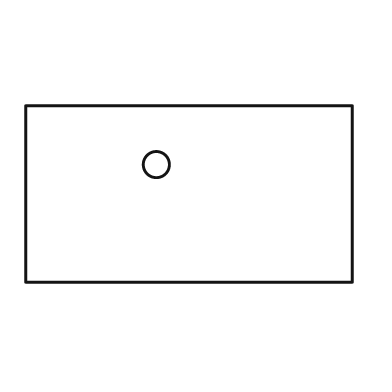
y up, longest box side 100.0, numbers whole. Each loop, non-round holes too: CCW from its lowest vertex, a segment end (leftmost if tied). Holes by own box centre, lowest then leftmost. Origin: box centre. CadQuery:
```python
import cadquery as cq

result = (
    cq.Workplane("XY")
    .moveTo(-50.0, -27.0)
    .lineTo(50.0, -27.0)
    .lineTo(50.0, 27.0)
    .lineTo(-50.0, 27.0)
    .close()
    .moveTo(-10.0, 9.0)
    .circle(4.0)
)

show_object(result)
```